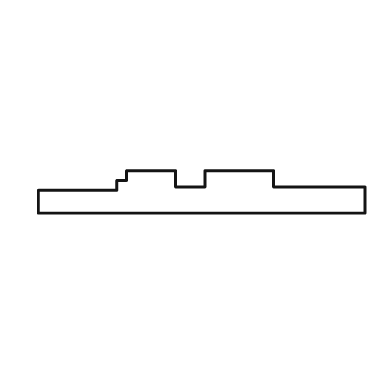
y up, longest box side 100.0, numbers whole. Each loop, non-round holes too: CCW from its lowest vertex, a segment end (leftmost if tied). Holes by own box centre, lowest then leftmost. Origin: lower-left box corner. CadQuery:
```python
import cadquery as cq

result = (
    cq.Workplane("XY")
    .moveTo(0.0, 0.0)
    .lineTo(100.0, 0.0)
    .lineTo(100.0, 8.0)
    .lineTo(72.0, 8.0)
    .lineTo(72.0, 13.0)
    .lineTo(51.0, 13.0)
    .lineTo(51.0, 8.0)
    .lineTo(42.0, 8.0)
    .lineTo(42.0, 13.0)
    .lineTo(27.0, 13.0)
    .lineTo(27.0, 10.0)
    .lineTo(24.0, 10.0)
    .lineTo(24.0, 7.0)
    .lineTo(0.0, 7.0)
    .close()
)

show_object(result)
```